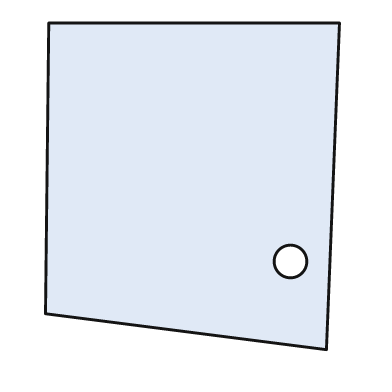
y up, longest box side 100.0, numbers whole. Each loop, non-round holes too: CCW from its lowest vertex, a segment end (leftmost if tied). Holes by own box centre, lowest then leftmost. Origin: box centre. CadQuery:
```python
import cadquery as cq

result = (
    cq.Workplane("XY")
    .moveTo(41.0, -50.0)
    .lineTo(45.0, 50.0)
    .lineTo(-44.0, 50.0)
    .lineTo(-45.0, -39.0)
    .close()
    .moveTo(30.0, -23.0)
    .circle(5.0)
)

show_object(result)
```